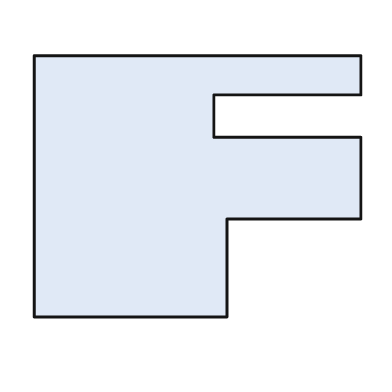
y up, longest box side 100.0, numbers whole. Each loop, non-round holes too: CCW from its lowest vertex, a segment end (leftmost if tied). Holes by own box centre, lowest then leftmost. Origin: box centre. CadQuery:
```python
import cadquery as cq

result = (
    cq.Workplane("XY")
    .moveTo(-50.0, -40.0)
    .lineTo(9.0, -40.0)
    .lineTo(9.0, -10.0)
    .lineTo(50.0, -10.0)
    .lineTo(50.0, 15.0)
    .lineTo(5.0, 15.0)
    .lineTo(5.0, 28.0)
    .lineTo(50.0, 28.0)
    .lineTo(50.0, 40.0)
    .lineTo(-50.0, 40.0)
    .close()
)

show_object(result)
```